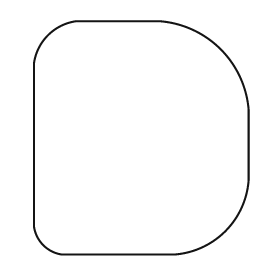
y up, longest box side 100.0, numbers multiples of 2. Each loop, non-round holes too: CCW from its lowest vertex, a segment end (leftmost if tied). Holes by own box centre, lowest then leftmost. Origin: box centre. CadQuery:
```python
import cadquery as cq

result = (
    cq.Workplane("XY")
    .moveTo(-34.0, -50.0)
    .lineTo(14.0, -50.0)
    .threePointArc((36.0, -40.0), (46.0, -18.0))
    .lineTo(46.0, 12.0)
    .threePointArc((34.0, 38.0), (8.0, 50.0))
    .lineTo(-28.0, 50.0)
    .threePointArc((-40.0, 44.0), (-46.0, 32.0))
    .lineTo(-46.0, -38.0)
    .threePointArc((-42.0, -46.0), (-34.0, -50.0))
    .close()
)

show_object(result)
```